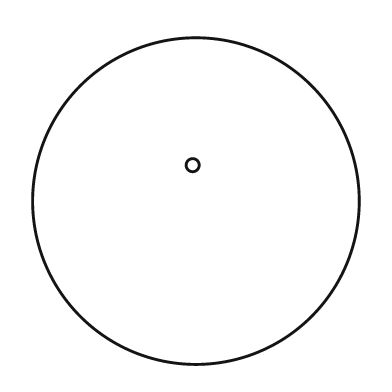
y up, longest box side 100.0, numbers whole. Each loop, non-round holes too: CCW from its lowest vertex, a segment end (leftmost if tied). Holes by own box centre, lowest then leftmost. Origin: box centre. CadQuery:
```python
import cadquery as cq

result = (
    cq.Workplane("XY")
    .moveTo(0.0, 0.0)
    .circle(50.0)
    .moveTo(-1.0, 11.0)
    .circle(2.0)
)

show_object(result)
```